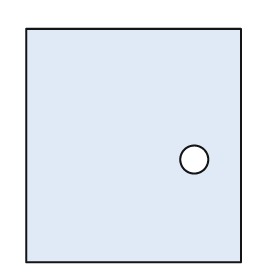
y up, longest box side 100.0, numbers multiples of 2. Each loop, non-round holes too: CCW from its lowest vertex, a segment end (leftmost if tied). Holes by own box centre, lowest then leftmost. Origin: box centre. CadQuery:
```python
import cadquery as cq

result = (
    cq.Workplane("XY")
    .moveTo(-46.0, -50.0)
    .lineTo(46.0, -50.0)
    .lineTo(46.0, 50.0)
    .lineTo(-46.0, 50.0)
    .close()
    .moveTo(26.0, -6.0)
    .circle(6.0)
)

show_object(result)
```